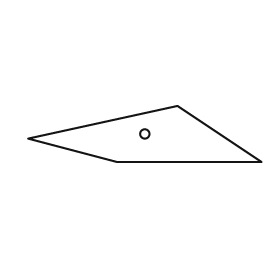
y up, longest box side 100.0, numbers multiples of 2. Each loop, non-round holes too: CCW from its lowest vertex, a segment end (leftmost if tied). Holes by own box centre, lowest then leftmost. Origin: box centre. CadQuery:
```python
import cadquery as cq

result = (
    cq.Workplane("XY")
    .moveTo(-12.0, -12.0)
    .lineTo(50.0, -12.0)
    .lineTo(14.0, 12.0)
    .lineTo(-50.0, -2.0)
    .close()
    .moveTo(0.0, 0.0)
    .circle(2.0)
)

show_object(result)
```